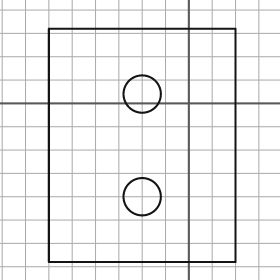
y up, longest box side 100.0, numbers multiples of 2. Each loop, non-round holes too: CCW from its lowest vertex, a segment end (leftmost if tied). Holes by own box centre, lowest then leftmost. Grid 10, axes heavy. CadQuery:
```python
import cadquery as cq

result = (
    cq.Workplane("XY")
    .moveTo(-60.0, -68.0)
    .lineTo(20.0, -68.0)
    .lineTo(20.0, 32.0)
    .lineTo(-60.0, 32.0)
    .close()
    .moveTo(-20.0, -40.0)
    .circle(8.0)
    .moveTo(-20.0, 4.0)
    .circle(8.0)
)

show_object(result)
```